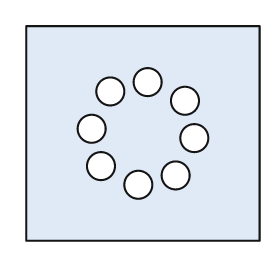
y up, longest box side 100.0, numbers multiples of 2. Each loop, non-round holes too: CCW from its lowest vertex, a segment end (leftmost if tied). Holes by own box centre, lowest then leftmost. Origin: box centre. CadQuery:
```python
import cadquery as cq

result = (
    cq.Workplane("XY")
    .moveTo(-50.0, -46.0)
    .lineTo(50.0, -46.0)
    .lineTo(50.0, 46.0)
    .lineTo(-50.0, 46.0)
    .close()
    .moveTo(-2.0, -22.0)
    .circle(6.0)
    .moveTo(14.0, -18.0)
    .circle(6.0)
    .moveTo(-18.0, -14.0)
    .circle(6.0)
    .moveTo(22.0, -2.0)
    .circle(6.0)
    .moveTo(-22.0, 2.0)
    .circle(6.0)
    .moveTo(18.0, 14.0)
    .circle(6.0)
    .moveTo(-14.0, 18.0)
    .circle(6.0)
    .moveTo(2.0, 22.0)
    .circle(6.0)
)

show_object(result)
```